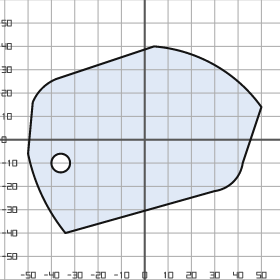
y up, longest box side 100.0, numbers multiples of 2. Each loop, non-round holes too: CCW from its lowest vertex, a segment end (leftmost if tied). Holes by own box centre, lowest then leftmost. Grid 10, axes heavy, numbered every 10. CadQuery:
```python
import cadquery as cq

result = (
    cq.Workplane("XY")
    .moveTo(-34.0, -40.0)
    .lineTo(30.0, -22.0)
    .threePointArc((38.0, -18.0), (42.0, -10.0))
    .lineTo(50.0, 14.0)
    .threePointArc((30.0, 32.0), (4.0, 40.0))
    .lineTo(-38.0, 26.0)
    .threePointArc((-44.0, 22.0), (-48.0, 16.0))
    .lineTo(-50.0, -6.0)
    .threePointArc((-44.0, -24.0), (-34.0, -40.0))
    .close()
    .moveTo(-36.0, -10.0)
    .circle(4.0)
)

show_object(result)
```